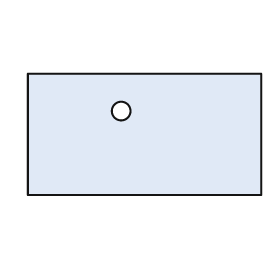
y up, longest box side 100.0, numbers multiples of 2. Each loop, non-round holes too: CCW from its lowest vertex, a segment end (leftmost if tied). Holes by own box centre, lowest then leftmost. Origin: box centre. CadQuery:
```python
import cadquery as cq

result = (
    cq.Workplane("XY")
    .moveTo(-50.0, -26.0)
    .lineTo(50.0, -26.0)
    .lineTo(50.0, 26.0)
    .lineTo(-50.0, 26.0)
    .close()
    .moveTo(-10.0, 10.0)
    .circle(4.0)
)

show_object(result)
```